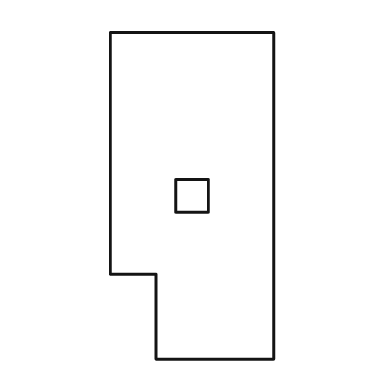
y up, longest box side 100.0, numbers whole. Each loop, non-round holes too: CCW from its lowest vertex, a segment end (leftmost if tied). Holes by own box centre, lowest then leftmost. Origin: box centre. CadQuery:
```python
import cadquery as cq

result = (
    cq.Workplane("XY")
    .moveTo(-11.0, -50.0)
    .lineTo(25.0, -50.0)
    .lineTo(25.0, 50.0)
    .lineTo(-25.0, 50.0)
    .lineTo(-25.0, -24.0)
    .lineTo(-11.0, -24.0)
    .close()
    .moveTo(-5.0, -5.0)
    .lineTo(5.0, -5.0)
    .lineTo(5.0, 5.0)
    .lineTo(-5.0, 5.0)
    .close()
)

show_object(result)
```